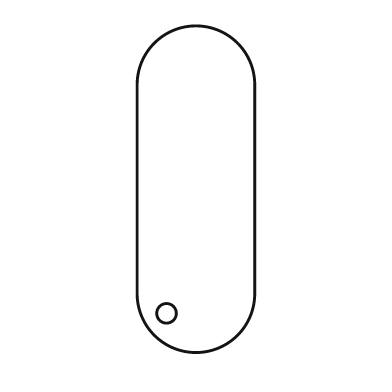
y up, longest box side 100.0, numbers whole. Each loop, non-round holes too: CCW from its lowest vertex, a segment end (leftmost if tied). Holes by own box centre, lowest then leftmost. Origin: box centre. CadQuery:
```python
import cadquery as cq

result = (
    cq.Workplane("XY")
    .moveTo(-18.0, -32.0)
    .threePointArc((0.0, -50.0), (18.0, -32.0))
    .lineTo(18.0, 32.0)
    .threePointArc((0.0, 50.0), (-18.0, 32.0))
    .close()
    .moveTo(-9.0, -38.0)
    .circle(3.0)
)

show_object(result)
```